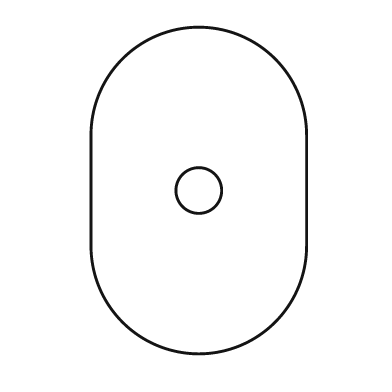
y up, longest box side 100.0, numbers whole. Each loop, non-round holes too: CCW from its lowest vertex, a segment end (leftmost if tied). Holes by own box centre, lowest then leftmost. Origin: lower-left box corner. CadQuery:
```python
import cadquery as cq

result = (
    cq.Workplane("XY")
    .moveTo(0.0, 33.0)
    .threePointArc((33.0, 0.0), (66.0, 33.0))
    .lineTo(66.0, 67.0)
    .threePointArc((33.0, 100.0), (0.0, 67.0))
    .close()
    .moveTo(33.0, 50.0)
    .circle(7.0)
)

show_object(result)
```